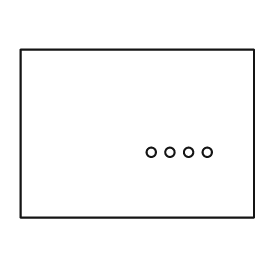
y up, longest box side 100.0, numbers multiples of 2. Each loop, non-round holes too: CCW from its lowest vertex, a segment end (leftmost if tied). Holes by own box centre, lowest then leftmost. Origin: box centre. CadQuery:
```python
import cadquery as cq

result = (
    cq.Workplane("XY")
    .moveTo(-50.0, -36.0)
    .lineTo(50.0, -36.0)
    .lineTo(50.0, 36.0)
    .lineTo(-50.0, 36.0)
    .close()
    .moveTo(6.0, -8.0)
    .circle(2.0)
    .moveTo(14.0, -8.0)
    .circle(2.0)
    .moveTo(22.0, -8.0)
    .circle(2.0)
    .moveTo(30.0, -8.0)
    .circle(2.0)
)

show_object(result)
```